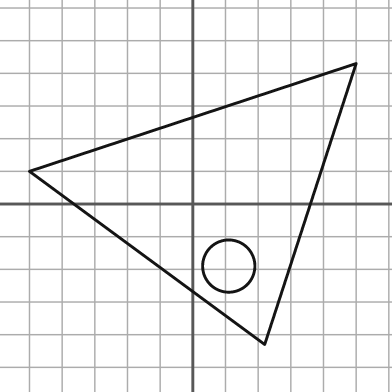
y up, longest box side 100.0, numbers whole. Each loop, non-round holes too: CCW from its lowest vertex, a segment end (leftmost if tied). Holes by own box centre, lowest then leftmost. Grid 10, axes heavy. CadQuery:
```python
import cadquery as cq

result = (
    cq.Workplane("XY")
    .moveTo(22.0, -43.0)
    .lineTo(50.0, 43.0)
    .lineTo(-50.0, 10.0)
    .close()
    .moveTo(11.0, -19.0)
    .circle(8.0)
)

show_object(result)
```